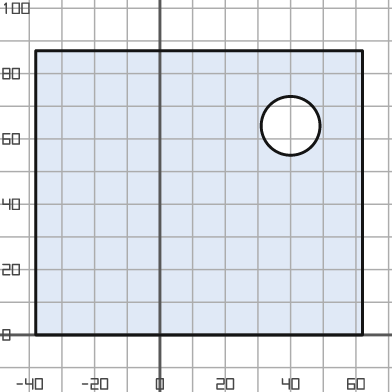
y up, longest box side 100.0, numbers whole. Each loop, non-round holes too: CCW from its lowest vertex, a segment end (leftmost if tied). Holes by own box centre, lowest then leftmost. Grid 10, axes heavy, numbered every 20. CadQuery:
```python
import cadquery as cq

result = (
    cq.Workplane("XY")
    .moveTo(-38.0, 0.0)
    .lineTo(62.0, 0.0)
    .lineTo(62.0, 87.0)
    .lineTo(-38.0, 87.0)
    .close()
    .moveTo(40.0, 64.0)
    .circle(9.0)
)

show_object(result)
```